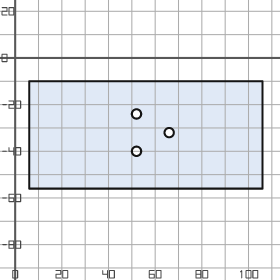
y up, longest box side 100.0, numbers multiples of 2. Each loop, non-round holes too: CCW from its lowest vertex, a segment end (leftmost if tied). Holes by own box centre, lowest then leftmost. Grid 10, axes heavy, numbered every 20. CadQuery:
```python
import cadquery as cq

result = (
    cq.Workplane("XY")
    .moveTo(6.0, -56.0)
    .lineTo(106.0, -56.0)
    .lineTo(106.0, -10.0)
    .lineTo(6.0, -10.0)
    .close()
    .moveTo(52.0, -40.0)
    .circle(2.0)
    .moveTo(66.0, -32.0)
    .circle(2.0)
    .moveTo(52.0, -24.0)
    .circle(2.0)
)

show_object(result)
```